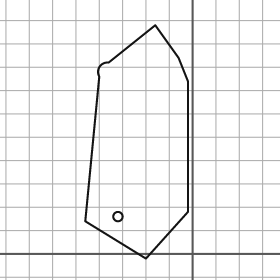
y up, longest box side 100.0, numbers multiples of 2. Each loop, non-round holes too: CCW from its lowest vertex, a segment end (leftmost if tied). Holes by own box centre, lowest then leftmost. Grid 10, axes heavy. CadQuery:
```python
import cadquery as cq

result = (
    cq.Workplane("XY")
    .moveTo(-20.0, -2.0)
    .lineTo(-2.0, 18.0)
    .lineTo(-2.0, 74.0)
    .lineTo(-6.0, 84.0)
    .lineTo(-16.0, 98.0)
    .lineTo(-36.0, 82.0)
    .threePointArc((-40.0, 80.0), (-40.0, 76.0))
    .lineTo(-46.0, 14.0)
    .close()
    .moveTo(-32.0, 16.0)
    .circle(2.0)
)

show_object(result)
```